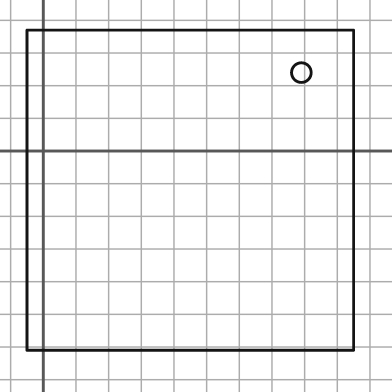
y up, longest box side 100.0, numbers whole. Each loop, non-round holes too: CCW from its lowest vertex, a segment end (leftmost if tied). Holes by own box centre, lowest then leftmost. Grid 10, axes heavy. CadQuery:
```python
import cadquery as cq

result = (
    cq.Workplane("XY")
    .moveTo(-5.0, -61.0)
    .lineTo(95.0, -61.0)
    .lineTo(95.0, 37.0)
    .lineTo(-5.0, 37.0)
    .close()
    .moveTo(79.0, 24.0)
    .circle(3.0)
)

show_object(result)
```